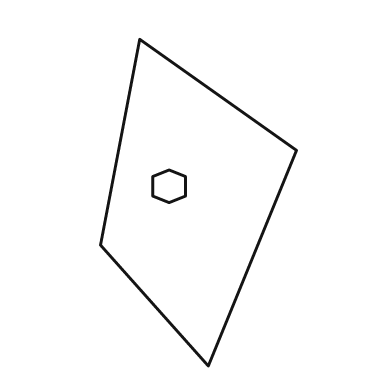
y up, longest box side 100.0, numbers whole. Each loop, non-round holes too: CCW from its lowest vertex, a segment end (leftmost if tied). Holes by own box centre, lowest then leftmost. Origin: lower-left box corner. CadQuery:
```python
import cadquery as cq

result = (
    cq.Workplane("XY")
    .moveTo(33.0, 0.0)
    .lineTo(60.0, 66.0)
    .lineTo(12.0, 100.0)
    .lineTo(0.0, 37.0)
    .close()
    .moveTo(21.0, 50.0)
    .lineTo(26.0, 52.0)
    .lineTo(26.0, 58.0)
    .lineTo(21.0, 60.0)
    .lineTo(16.0, 58.0)
    .lineTo(16.0, 52.0)
    .close()
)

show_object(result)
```